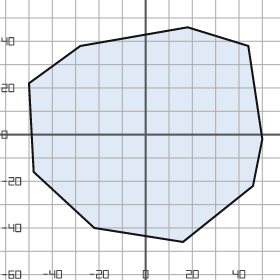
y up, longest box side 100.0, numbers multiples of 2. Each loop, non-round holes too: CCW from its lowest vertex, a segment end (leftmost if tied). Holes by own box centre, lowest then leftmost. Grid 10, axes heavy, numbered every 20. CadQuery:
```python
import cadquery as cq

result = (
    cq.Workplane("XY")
    .moveTo(16.0, -46.0)
    .lineTo(46.0, -22.0)
    .lineTo(50.0, -2.0)
    .lineTo(44.0, 38.0)
    .lineTo(18.0, 46.0)
    .lineTo(-28.0, 38.0)
    .lineTo(-50.0, 22.0)
    .lineTo(-48.0, -16.0)
    .lineTo(-22.0, -40.0)
    .close()
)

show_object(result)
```